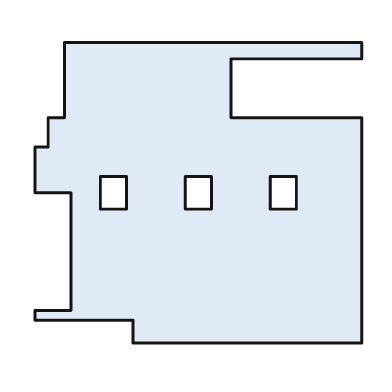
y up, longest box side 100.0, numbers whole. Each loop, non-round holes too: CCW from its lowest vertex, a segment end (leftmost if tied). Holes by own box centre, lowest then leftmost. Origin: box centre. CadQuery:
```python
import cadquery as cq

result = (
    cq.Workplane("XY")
    .moveTo(-20.0, -46.0)
    .lineTo(50.0, -46.0)
    .lineTo(50.0, 23.0)
    .lineTo(10.0, 23.0)
    .lineTo(10.0, 41.0)
    .lineTo(50.0, 41.0)
    .lineTo(50.0, 46.0)
    .lineTo(-41.0, 46.0)
    .lineTo(-41.0, 23.0)
    .lineTo(-46.0, 23.0)
    .lineTo(-46.0, 14.0)
    .lineTo(-50.0, 14.0)
    .lineTo(-50.0, 0.0)
    .lineTo(-39.0, 0.0)
    .lineTo(-39.0, -36.0)
    .lineTo(-50.0, -36.0)
    .lineTo(-50.0, -39.0)
    .lineTo(-20.0, -39.0)
    .close()
    .moveTo(-30.0, -5.0)
    .lineTo(-22.0, -5.0)
    .lineTo(-22.0, 5.0)
    .lineTo(-30.0, 5.0)
    .close()
    .moveTo(-4.0, -5.0)
    .lineTo(4.0, -5.0)
    .lineTo(4.0, 5.0)
    .lineTo(-4.0, 5.0)
    .close()
    .moveTo(22.0, -5.0)
    .lineTo(30.0, -5.0)
    .lineTo(30.0, 5.0)
    .lineTo(22.0, 5.0)
    .close()
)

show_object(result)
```